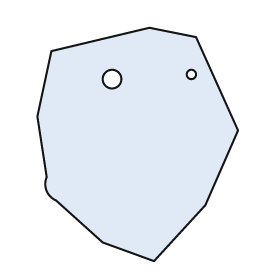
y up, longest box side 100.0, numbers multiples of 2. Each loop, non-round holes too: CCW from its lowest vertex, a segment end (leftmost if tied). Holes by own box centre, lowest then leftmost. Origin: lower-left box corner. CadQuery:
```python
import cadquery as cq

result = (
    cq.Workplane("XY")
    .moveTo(50.0, 0.0)
    .lineTo(72.0, 24.0)
    .lineTo(86.0, 56.0)
    .lineTo(68.0, 96.0)
    .lineTo(48.0, 100.0)
    .lineTo(6.0, 90.0)
    .lineTo(0.0, 62.0)
    .lineTo(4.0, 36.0)
    .threePointArc((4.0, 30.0), (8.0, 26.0))
    .lineTo(28.0, 8.0)
    .close()
    .moveTo(32.0, 78.0)
    .circle(4.0)
    .moveTo(66.0, 80.0)
    .circle(2.0)
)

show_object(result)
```